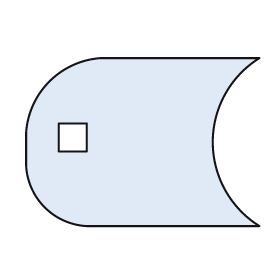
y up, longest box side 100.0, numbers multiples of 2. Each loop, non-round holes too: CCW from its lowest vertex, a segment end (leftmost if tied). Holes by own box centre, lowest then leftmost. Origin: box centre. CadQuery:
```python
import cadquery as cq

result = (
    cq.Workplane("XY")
    .moveTo(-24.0, -36.0)
    .lineTo(50.0, -36.0)
    .threePointArc((30.0, 0.0), (50.0, 36.0))
    .lineTo(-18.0, 36.0)
    .threePointArc((-40.0, 26.0), (-50.0, 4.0))
    .lineTo(-50.0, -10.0)
    .threePointArc((-42.0, -28.0), (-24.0, -36.0))
    .close()
    .moveTo(-36.0, -4.0)
    .lineTo(-24.0, -4.0)
    .lineTo(-24.0, 8.0)
    .lineTo(-36.0, 8.0)
    .close()
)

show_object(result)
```